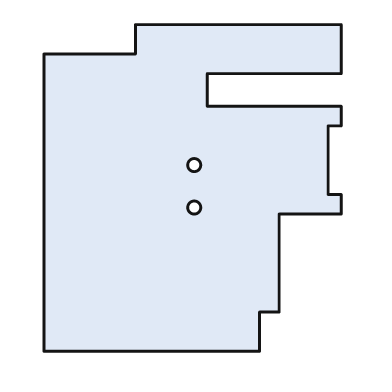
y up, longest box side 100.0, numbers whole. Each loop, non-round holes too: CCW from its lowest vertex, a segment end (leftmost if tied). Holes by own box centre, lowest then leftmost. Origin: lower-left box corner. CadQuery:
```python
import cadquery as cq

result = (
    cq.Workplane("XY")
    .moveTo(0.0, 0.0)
    .lineTo(66.0, 0.0)
    .lineTo(66.0, 12.0)
    .lineTo(72.0, 12.0)
    .lineTo(72.0, 42.0)
    .lineTo(91.0, 42.0)
    .lineTo(91.0, 48.0)
    .lineTo(87.0, 48.0)
    .lineTo(87.0, 69.0)
    .lineTo(91.0, 69.0)
    .lineTo(91.0, 75.0)
    .lineTo(50.0, 75.0)
    .lineTo(50.0, 85.0)
    .lineTo(91.0, 85.0)
    .lineTo(91.0, 100.0)
    .lineTo(28.0, 100.0)
    .lineTo(28.0, 91.0)
    .lineTo(0.0, 91.0)
    .close()
    .moveTo(46.0, 44.0)
    .circle(2.0)
    .moveTo(46.0, 57.0)
    .circle(2.0)
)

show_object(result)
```